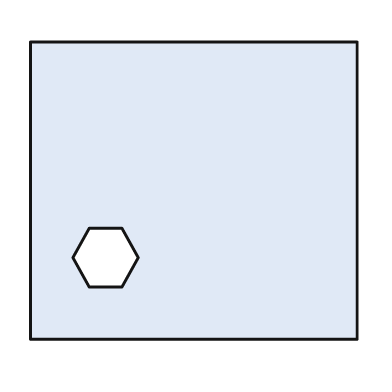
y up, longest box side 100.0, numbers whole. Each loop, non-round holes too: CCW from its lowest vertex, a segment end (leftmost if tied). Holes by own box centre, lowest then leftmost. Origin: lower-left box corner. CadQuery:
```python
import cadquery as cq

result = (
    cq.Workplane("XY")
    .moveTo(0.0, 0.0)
    .lineTo(100.0, 0.0)
    .lineTo(100.0, 91.0)
    .lineTo(0.0, 91.0)
    .close()
    .moveTo(18.0, 16.0)
    .lineTo(28.0, 16.0)
    .lineTo(33.0, 25.0)
    .lineTo(28.0, 34.0)
    .lineTo(18.0, 34.0)
    .lineTo(13.0, 25.0)
    .close()
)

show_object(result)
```